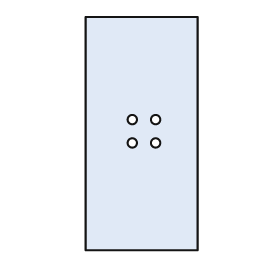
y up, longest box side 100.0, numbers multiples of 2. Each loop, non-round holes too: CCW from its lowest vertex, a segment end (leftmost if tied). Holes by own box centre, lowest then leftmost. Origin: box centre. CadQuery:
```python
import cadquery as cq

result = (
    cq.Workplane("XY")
    .moveTo(-24.0, -50.0)
    .lineTo(24.0, -50.0)
    .lineTo(24.0, 50.0)
    .lineTo(-24.0, 50.0)
    .close()
    .moveTo(-4.0, -4.0)
    .circle(2.0)
    .moveTo(6.0, -4.0)
    .circle(2.0)
    .moveTo(-4.0, 6.0)
    .circle(2.0)
    .moveTo(6.0, 6.0)
    .circle(2.0)
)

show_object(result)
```